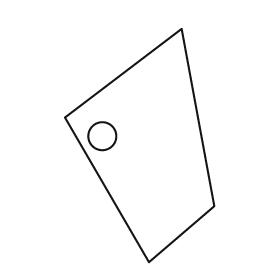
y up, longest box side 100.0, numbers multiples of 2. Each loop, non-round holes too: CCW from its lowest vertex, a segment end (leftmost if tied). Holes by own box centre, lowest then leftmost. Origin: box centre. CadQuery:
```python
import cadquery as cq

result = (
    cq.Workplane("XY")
    .moveTo(4.0, -50.0)
    .lineTo(32.0, -26.0)
    .lineTo(18.0, 50.0)
    .lineTo(-32.0, 12.0)
    .close()
    .moveTo(-16.0, 4.0)
    .circle(6.0)
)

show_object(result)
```